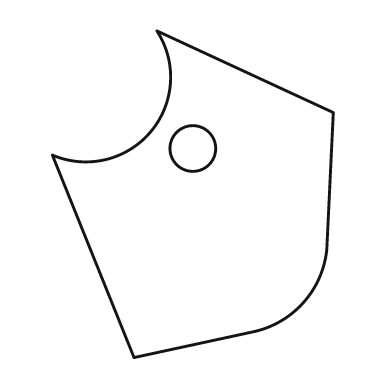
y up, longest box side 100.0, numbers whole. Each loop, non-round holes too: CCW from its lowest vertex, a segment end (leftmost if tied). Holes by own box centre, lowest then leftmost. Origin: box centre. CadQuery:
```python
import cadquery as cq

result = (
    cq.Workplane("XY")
    .moveTo(-18.0, -50.0)
    .lineTo(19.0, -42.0)
    .threePointArc((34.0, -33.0), (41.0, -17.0))
    .lineTo(43.0, 25.0)
    .lineTo(-11.0, 50.0)
    .threePointArc((-13.0, 19.0), (-43.0, 12.0))
    .close()
    .moveTo(0.0, 14.0)
    .circle(7.0)
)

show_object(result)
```